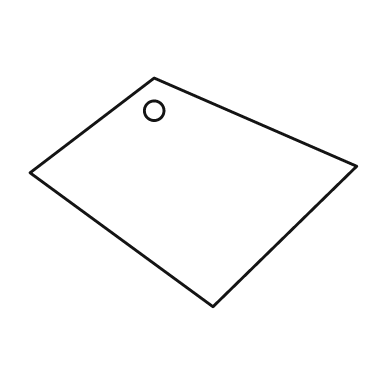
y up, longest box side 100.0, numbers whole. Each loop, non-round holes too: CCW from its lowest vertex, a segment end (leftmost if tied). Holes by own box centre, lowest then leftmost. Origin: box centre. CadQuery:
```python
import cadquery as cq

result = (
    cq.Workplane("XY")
    .moveTo(6.0, -35.0)
    .lineTo(50.0, 8.0)
    .lineTo(-12.0, 35.0)
    .lineTo(-50.0, 6.0)
    .close()
    .moveTo(-12.0, 25.0)
    .circle(3.0)
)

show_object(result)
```